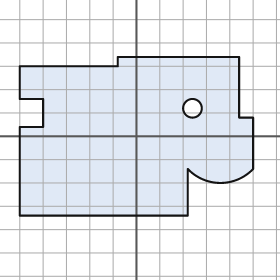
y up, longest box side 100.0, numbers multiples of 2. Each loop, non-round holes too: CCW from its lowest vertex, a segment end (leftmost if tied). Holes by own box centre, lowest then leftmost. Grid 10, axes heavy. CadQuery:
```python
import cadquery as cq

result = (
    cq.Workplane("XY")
    .moveTo(-50.0, -34.0)
    .lineTo(22.0, -34.0)
    .lineTo(22.0, -14.0)
    .threePointArc((36.0, -20.0), (50.0, -14.0))
    .lineTo(50.0, 8.0)
    .lineTo(44.0, 8.0)
    .lineTo(44.0, 34.0)
    .lineTo(-8.0, 34.0)
    .lineTo(-8.0, 30.0)
    .lineTo(-50.0, 30.0)
    .lineTo(-50.0, 16.0)
    .lineTo(-40.0, 16.0)
    .lineTo(-40.0, 4.0)
    .lineTo(-50.0, 4.0)
    .close()
    .moveTo(24.0, 12.0)
    .circle(4.0)
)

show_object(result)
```